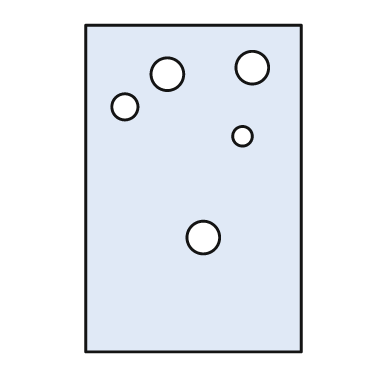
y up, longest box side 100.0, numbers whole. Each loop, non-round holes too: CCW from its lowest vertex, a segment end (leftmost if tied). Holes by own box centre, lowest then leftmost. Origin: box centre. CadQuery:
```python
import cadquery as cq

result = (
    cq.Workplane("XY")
    .moveTo(-33.0, -50.0)
    .lineTo(33.0, -50.0)
    .lineTo(33.0, 50.0)
    .lineTo(-33.0, 50.0)
    .close()
    .moveTo(3.0, -15.0)
    .circle(5.0)
    .moveTo(15.0, 16.0)
    .circle(3.0)
    .moveTo(-21.0, 25.0)
    .circle(4.0)
    .moveTo(-8.0, 35.0)
    .circle(5.0)
    .moveTo(18.0, 37.0)
    .circle(5.0)
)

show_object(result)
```